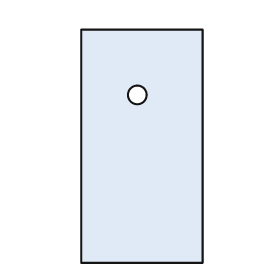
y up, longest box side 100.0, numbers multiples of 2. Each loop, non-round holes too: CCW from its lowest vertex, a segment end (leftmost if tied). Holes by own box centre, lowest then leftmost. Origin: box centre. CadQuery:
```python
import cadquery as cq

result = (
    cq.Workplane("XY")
    .moveTo(-26.0, -50.0)
    .lineTo(26.0, -50.0)
    .lineTo(26.0, 50.0)
    .lineTo(-26.0, 50.0)
    .close()
    .moveTo(-2.0, 22.0)
    .circle(4.0)
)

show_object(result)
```